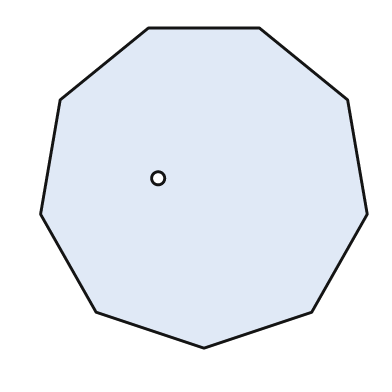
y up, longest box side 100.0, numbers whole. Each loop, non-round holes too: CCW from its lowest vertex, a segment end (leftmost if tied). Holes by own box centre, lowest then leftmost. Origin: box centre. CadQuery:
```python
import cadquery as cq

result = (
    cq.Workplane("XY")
    .moveTo(0.0, -49.0)
    .lineTo(33.0, -38.0)
    .lineTo(50.0, -8.0)
    .lineTo(44.0, 27.0)
    .lineTo(17.0, 49.0)
    .lineTo(-17.0, 49.0)
    .lineTo(-44.0, 27.0)
    .lineTo(-50.0, -8.0)
    .lineTo(-33.0, -38.0)
    .close()
    .moveTo(-14.0, 3.0)
    .circle(2.0)
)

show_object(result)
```